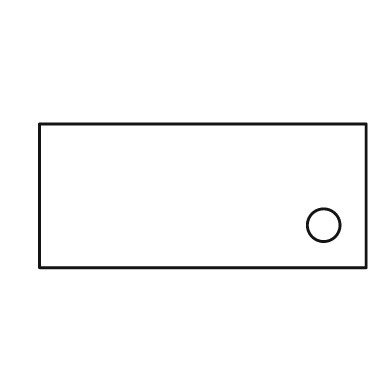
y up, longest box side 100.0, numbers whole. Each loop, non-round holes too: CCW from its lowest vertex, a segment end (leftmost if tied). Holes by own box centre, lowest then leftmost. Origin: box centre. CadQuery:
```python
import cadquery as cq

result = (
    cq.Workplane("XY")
    .moveTo(-50.0, -22.0)
    .lineTo(50.0, -22.0)
    .lineTo(50.0, 22.0)
    .lineTo(-50.0, 22.0)
    .close()
    .moveTo(37.0, -9.0)
    .circle(5.0)
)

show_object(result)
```